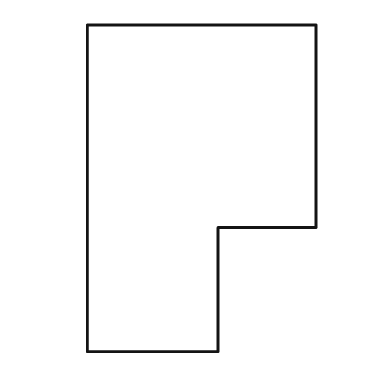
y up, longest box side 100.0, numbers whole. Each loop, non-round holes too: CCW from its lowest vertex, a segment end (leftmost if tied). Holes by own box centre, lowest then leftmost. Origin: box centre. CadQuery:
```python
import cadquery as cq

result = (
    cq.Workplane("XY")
    .moveTo(-35.0, -50.0)
    .lineTo(5.0, -50.0)
    .lineTo(5.0, -12.0)
    .lineTo(35.0, -12.0)
    .lineTo(35.0, 50.0)
    .lineTo(-35.0, 50.0)
    .close()
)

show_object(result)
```